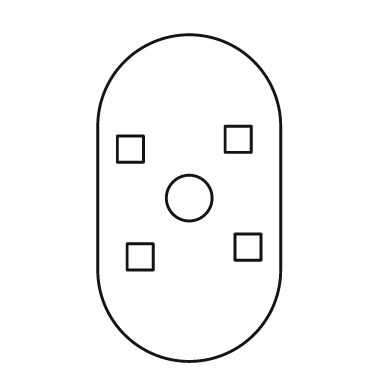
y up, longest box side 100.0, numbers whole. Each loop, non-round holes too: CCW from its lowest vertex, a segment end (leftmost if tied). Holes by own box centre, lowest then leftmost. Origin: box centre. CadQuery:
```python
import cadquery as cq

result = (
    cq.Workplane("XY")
    .moveTo(-28.0, -22.0)
    .threePointArc((0.0, -50.0), (28.0, -22.0))
    .lineTo(28.0, 22.0)
    .threePointArc((0.0, 50.0), (-28.0, 22.0))
    .close()
    .moveTo(-19.0, -22.0)
    .lineTo(-11.0, -22.0)
    .lineTo(-11.0, -14.0)
    .lineTo(-19.0, -14.0)
    .close()
    .moveTo(14.0, -19.0)
    .lineTo(22.0, -19.0)
    .lineTo(22.0, -11.0)
    .lineTo(14.0, -11.0)
    .close()
    .moveTo(0.0, 0.0)
    .circle(7.0)
    .moveTo(-22.0, 11.0)
    .lineTo(-14.0, 11.0)
    .lineTo(-14.0, 19.0)
    .lineTo(-22.0, 19.0)
    .close()
    .moveTo(11.0, 14.0)
    .lineTo(19.0, 14.0)
    .lineTo(19.0, 22.0)
    .lineTo(11.0, 22.0)
    .close()
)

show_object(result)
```